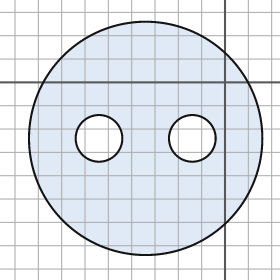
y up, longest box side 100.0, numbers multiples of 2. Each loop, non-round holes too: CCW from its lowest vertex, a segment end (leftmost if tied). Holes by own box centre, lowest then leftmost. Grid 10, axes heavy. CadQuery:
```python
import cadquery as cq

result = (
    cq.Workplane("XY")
    .moveTo(-34.0, -24.0)
    .circle(50.0)
    .moveTo(-54.0, -24.0)
    .circle(10.0)
    .moveTo(-14.0, -24.0)
    .circle(10.0)
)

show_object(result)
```